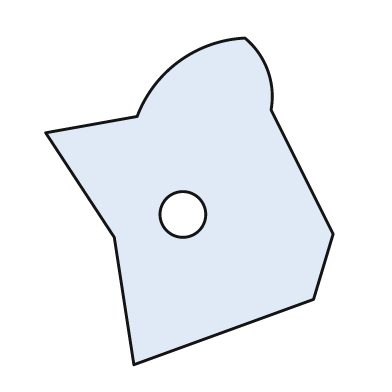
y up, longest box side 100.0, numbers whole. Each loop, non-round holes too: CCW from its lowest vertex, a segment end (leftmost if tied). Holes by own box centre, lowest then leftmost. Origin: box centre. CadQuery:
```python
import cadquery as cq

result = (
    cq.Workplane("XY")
    .moveTo(-17.0, -50.0)
    .lineTo(38.0, -30.0)
    .lineTo(44.0, -10.0)
    .lineTo(25.0, 28.0)
    .threePointArc((24.0, 40.0), (17.0, 50.0))
    .threePointArc((-3.0, 43.0), (-16.0, 26.0))
    .lineTo(-44.0, 21.0)
    .lineTo(-23.0, -11.0)
    .close()
    .moveTo(-2.0, -4.0)
    .circle(7.0)
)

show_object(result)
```